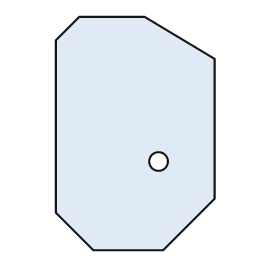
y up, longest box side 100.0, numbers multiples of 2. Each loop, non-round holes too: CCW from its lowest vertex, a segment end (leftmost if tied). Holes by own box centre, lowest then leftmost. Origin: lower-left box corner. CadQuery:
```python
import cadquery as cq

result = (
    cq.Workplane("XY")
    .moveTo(16.0, 0.0)
    .lineTo(46.0, 0.0)
    .lineTo(68.0, 22.0)
    .lineTo(68.0, 82.0)
    .lineTo(38.0, 100.0)
    .lineTo(10.0, 100.0)
    .lineTo(0.0, 90.0)
    .lineTo(0.0, 16.0)
    .close()
    .moveTo(44.0, 38.0)
    .circle(4.0)
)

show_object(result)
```